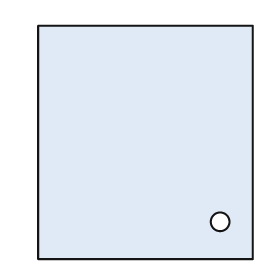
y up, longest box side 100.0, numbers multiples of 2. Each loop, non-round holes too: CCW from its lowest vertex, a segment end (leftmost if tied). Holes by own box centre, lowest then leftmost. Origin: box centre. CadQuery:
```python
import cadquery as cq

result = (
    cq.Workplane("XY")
    .moveTo(-46.0, -50.0)
    .lineTo(46.0, -50.0)
    .lineTo(46.0, 50.0)
    .lineTo(-46.0, 50.0)
    .close()
    .moveTo(32.0, -34.0)
    .circle(4.0)
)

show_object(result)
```